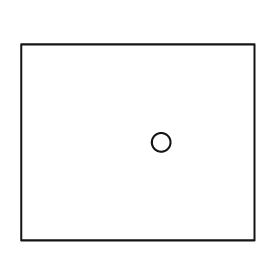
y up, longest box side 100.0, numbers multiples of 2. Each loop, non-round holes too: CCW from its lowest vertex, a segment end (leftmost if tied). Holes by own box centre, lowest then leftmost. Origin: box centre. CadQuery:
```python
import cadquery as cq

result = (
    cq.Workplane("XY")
    .moveTo(-50.0, -42.0)
    .lineTo(50.0, -42.0)
    .lineTo(50.0, 42.0)
    .lineTo(-50.0, 42.0)
    .close()
    .moveTo(10.0, 0.0)
    .circle(4.0)
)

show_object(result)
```